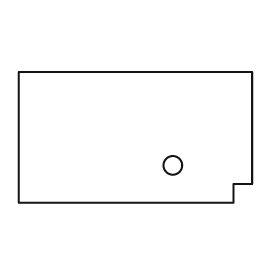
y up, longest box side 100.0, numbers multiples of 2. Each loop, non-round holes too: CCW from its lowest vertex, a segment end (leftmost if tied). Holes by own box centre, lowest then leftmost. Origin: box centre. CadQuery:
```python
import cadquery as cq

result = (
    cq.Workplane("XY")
    .moveTo(-50.0, -28.0)
    .lineTo(42.0, -28.0)
    .lineTo(42.0, -20.0)
    .lineTo(50.0, -20.0)
    .lineTo(50.0, 28.0)
    .lineTo(-50.0, 28.0)
    .close()
    .moveTo(16.0, -12.0)
    .circle(4.0)
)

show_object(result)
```